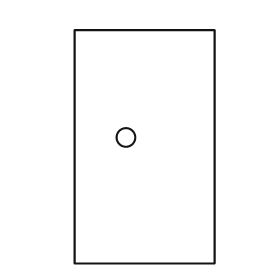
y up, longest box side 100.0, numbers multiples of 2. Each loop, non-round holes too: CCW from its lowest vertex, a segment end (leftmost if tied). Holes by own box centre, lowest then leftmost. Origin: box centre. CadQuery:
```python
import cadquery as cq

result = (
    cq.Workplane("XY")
    .moveTo(-30.0, -50.0)
    .lineTo(30.0, -50.0)
    .lineTo(30.0, 50.0)
    .lineTo(-30.0, 50.0)
    .close()
    .moveTo(-8.0, 4.0)
    .circle(4.0)
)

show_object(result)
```